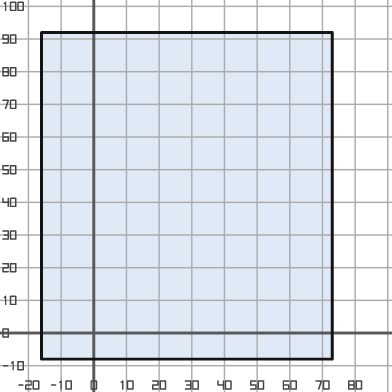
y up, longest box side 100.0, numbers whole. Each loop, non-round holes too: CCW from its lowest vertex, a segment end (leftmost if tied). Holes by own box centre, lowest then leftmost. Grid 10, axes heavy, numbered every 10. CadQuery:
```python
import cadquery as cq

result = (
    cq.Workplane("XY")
    .moveTo(-16.0, -8.0)
    .lineTo(73.0, -8.0)
    .lineTo(73.0, 92.0)
    .lineTo(-16.0, 92.0)
    .close()
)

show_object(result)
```